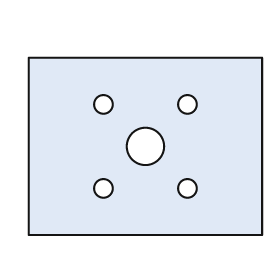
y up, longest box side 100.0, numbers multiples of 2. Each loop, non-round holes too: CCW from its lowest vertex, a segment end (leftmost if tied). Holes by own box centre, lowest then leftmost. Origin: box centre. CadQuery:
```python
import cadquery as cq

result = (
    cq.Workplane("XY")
    .moveTo(-50.0, -38.0)
    .lineTo(50.0, -38.0)
    .lineTo(50.0, 38.0)
    .lineTo(-50.0, 38.0)
    .close()
    .moveTo(-18.0, -18.0)
    .circle(4.0)
    .moveTo(18.0, -18.0)
    .circle(4.0)
    .moveTo(0.0, 0.0)
    .circle(8.0)
    .moveTo(-18.0, 18.0)
    .circle(4.0)
    .moveTo(18.0, 18.0)
    .circle(4.0)
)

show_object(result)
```